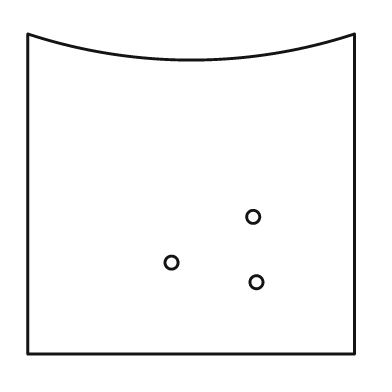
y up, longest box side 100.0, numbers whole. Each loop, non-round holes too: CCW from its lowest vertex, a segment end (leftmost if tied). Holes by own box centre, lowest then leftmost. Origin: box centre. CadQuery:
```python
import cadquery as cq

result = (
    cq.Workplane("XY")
    .moveTo(-50.0, -49.0)
    .lineTo(50.0, -49.0)
    .lineTo(50.0, 49.0)
    .threePointArc((0.0, 41.0), (-50.0, 49.0))
    .close()
    .moveTo(20.0, -27.0)
    .circle(2.0)
    .moveTo(-6.0, -21.0)
    .circle(2.0)
    .moveTo(19.0, -7.0)
    .circle(2.0)
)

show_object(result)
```